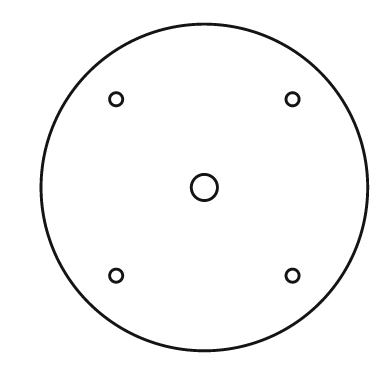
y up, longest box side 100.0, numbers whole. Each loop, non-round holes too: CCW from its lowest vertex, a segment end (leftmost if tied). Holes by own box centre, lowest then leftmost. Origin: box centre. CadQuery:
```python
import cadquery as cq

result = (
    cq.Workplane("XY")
    .moveTo(0.0, 0.0)
    .circle(50.0)
    .moveTo(-27.0, -27.0)
    .circle(2.0)
    .moveTo(27.0, -27.0)
    .circle(2.0)
    .moveTo(0.0, 0.0)
    .circle(4.0)
    .moveTo(-27.0, 27.0)
    .circle(2.0)
    .moveTo(27.0, 27.0)
    .circle(2.0)
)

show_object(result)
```